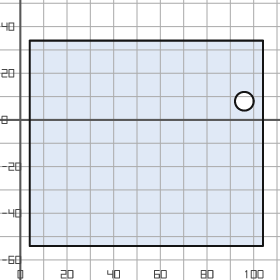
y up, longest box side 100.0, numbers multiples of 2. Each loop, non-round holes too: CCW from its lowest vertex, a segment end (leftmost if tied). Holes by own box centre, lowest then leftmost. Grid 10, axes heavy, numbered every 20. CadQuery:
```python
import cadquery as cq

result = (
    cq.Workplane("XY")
    .moveTo(4.0, -54.0)
    .lineTo(104.0, -54.0)
    .lineTo(104.0, 34.0)
    .lineTo(4.0, 34.0)
    .close()
    .moveTo(96.0, 8.0)
    .circle(4.0)
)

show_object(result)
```